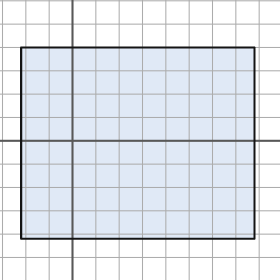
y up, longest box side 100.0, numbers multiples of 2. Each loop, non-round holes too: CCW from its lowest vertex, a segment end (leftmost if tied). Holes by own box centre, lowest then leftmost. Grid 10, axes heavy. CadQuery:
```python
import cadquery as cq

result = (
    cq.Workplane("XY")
    .moveTo(-22.0, -42.0)
    .lineTo(78.0, -42.0)
    .lineTo(78.0, 40.0)
    .lineTo(-22.0, 40.0)
    .close()
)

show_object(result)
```